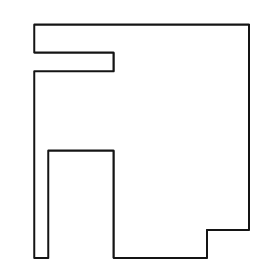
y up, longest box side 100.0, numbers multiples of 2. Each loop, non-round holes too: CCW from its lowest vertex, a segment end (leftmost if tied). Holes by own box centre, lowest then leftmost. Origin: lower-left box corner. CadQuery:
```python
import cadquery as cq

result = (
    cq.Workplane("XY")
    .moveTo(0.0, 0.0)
    .lineTo(6.0, 0.0)
    .lineTo(6.0, 46.0)
    .lineTo(34.0, 46.0)
    .lineTo(34.0, 0.0)
    .lineTo(74.0, 0.0)
    .lineTo(74.0, 12.0)
    .lineTo(92.0, 12.0)
    .lineTo(92.0, 100.0)
    .lineTo(0.0, 100.0)
    .lineTo(0.0, 88.0)
    .lineTo(34.0, 88.0)
    .lineTo(34.0, 80.0)
    .lineTo(0.0, 80.0)
    .close()
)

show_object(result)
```